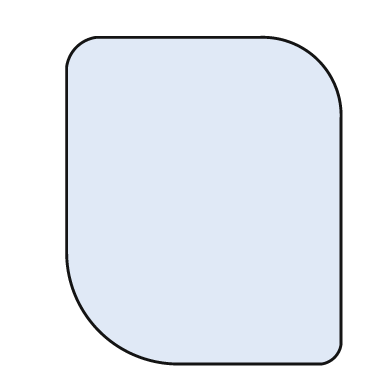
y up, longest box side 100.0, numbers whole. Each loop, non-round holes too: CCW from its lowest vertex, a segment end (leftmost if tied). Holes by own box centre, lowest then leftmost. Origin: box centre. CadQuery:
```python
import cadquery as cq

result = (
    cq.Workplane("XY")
    .moveTo(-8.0, -50.0)
    .lineTo(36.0, -50.0)
    .threePointArc((40.0, -48.0), (42.0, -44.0))
    .lineTo(42.0, 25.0)
    .threePointArc((35.0, 43.0), (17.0, 50.0))
    .lineTo(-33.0, 50.0)
    .threePointArc((-39.0, 47.0), (-42.0, 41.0))
    .lineTo(-42.0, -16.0)
    .threePointArc((-32.0, -40.0), (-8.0, -50.0))
    .close()
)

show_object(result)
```